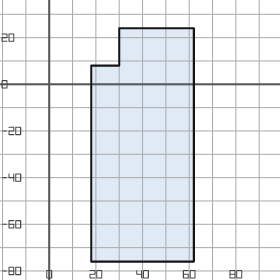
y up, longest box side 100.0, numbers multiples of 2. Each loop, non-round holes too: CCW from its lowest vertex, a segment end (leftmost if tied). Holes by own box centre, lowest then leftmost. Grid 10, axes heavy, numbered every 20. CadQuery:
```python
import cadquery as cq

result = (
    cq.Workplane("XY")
    .moveTo(18.0, -76.0)
    .lineTo(62.0, -76.0)
    .lineTo(62.0, 24.0)
    .lineTo(30.0, 24.0)
    .lineTo(30.0, 8.0)
    .lineTo(18.0, 8.0)
    .close()
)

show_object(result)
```